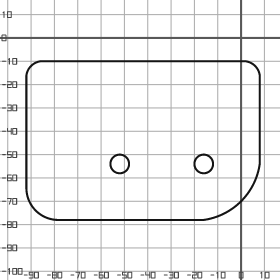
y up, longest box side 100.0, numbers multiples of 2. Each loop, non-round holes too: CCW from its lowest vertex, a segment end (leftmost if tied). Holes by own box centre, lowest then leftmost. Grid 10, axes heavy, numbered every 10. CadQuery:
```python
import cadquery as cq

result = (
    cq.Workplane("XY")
    .moveTo(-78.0, -78.0)
    .lineTo(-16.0, -78.0)
    .threePointArc((0.0, -70.0), (8.0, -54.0))
    .lineTo(8.0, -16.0)
    .threePointArc((6.0, -12.0), (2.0, -10.0))
    .lineTo(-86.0, -10.0)
    .threePointArc((-90.0, -12.0), (-92.0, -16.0))
    .lineTo(-92.0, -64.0)
    .threePointArc((-88.0, -74.0), (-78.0, -78.0))
    .close()
    .moveTo(-52.0, -54.0)
    .circle(4.0)
    .moveTo(-16.0, -54.0)
    .circle(4.0)
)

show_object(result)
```